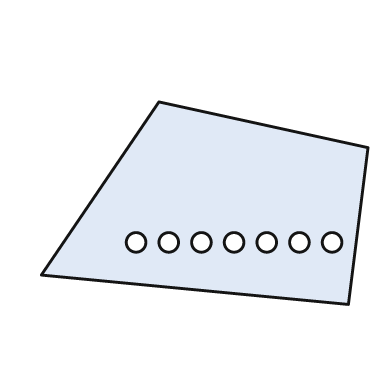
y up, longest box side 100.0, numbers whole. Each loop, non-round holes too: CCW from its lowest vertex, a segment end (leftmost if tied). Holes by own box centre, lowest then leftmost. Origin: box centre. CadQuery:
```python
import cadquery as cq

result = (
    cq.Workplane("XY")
    .moveTo(44.0, -31.0)
    .lineTo(50.0, 17.0)
    .lineTo(-14.0, 31.0)
    .lineTo(-50.0, -22.0)
    .close()
    .moveTo(-21.0, -12.0)
    .circle(3.0)
    .moveTo(-11.0, -12.0)
    .circle(3.0)
    .moveTo(-1.0, -12.0)
    .circle(3.0)
    .moveTo(9.0, -12.0)
    .circle(3.0)
    .moveTo(19.0, -12.0)
    .circle(3.0)
    .moveTo(29.0, -12.0)
    .circle(3.0)
    .moveTo(39.0, -12.0)
    .circle(3.0)
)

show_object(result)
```